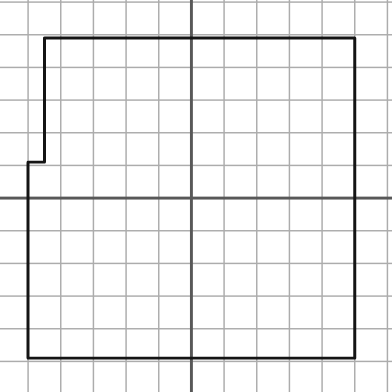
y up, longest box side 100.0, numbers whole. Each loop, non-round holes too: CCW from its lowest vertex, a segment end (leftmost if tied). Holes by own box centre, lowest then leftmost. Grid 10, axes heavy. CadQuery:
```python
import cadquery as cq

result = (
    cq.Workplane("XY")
    .moveTo(-50.0, -49.0)
    .lineTo(50.0, -49.0)
    .lineTo(50.0, 49.0)
    .lineTo(-45.0, 49.0)
    .lineTo(-45.0, 11.0)
    .lineTo(-50.0, 11.0)
    .close()
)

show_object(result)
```